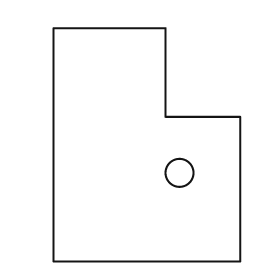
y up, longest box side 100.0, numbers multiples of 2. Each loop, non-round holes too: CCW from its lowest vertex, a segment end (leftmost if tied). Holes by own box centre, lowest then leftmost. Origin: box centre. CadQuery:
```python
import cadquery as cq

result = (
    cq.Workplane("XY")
    .moveTo(-40.0, -50.0)
    .lineTo(40.0, -50.0)
    .lineTo(40.0, 12.0)
    .lineTo(8.0, 12.0)
    .lineTo(8.0, 50.0)
    .lineTo(-40.0, 50.0)
    .close()
    .moveTo(14.0, -12.0)
    .circle(6.0)
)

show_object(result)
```